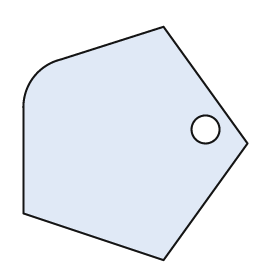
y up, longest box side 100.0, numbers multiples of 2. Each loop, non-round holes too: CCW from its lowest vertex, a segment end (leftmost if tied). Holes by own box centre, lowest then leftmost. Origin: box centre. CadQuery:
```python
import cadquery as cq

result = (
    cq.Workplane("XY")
    .moveTo(12.0, -50.0)
    .lineTo(48.0, 0.0)
    .lineTo(12.0, 50.0)
    .lineTo(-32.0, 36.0)
    .threePointArc((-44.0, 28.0), (-48.0, 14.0))
    .lineTo(-48.0, -30.0)
    .close()
    .moveTo(30.0, 6.0)
    .circle(6.0)
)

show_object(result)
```